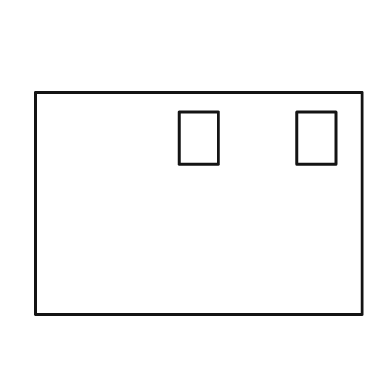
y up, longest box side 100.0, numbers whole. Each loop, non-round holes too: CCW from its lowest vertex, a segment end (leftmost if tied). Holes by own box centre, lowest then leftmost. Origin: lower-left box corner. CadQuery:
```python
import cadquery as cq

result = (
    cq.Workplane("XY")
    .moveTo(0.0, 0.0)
    .lineTo(100.0, 0.0)
    .lineTo(100.0, 68.0)
    .lineTo(0.0, 68.0)
    .close()
    .moveTo(44.0, 46.0)
    .lineTo(56.0, 46.0)
    .lineTo(56.0, 62.0)
    .lineTo(44.0, 62.0)
    .close()
    .moveTo(80.0, 46.0)
    .lineTo(92.0, 46.0)
    .lineTo(92.0, 62.0)
    .lineTo(80.0, 62.0)
    .close()
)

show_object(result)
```